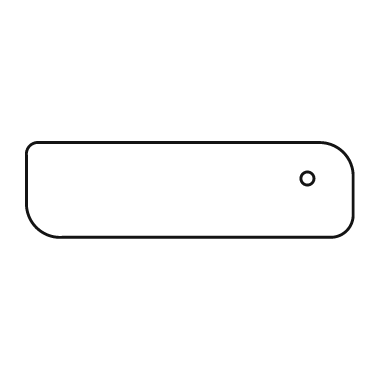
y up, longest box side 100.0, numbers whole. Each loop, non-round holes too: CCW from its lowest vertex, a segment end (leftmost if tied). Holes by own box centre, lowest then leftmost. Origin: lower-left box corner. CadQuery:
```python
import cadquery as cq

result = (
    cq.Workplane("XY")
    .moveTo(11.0, 0.0)
    .lineTo(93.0, 0.0)
    .threePointArc((98.0, 2.0), (100.0, 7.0))
    .lineTo(100.0, 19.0)
    .threePointArc((97.0, 26.0), (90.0, 29.0))
    .lineTo(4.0, 29.0)
    .threePointArc((1.0, 28.0), (0.0, 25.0))
    .lineTo(0.0, 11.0)
    .threePointArc((3.0, 3.0), (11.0, 0.0))
    .close()
    .moveTo(86.0, 18.0)
    .circle(2.0)
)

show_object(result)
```